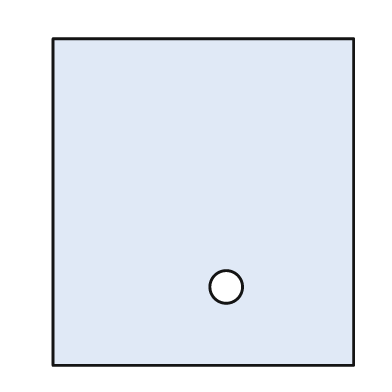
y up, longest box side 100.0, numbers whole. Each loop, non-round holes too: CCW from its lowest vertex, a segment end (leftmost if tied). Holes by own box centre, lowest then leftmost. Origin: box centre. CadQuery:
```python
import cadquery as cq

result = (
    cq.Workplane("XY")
    .moveTo(-46.0, -50.0)
    .lineTo(46.0, -50.0)
    .lineTo(46.0, 50.0)
    .lineTo(-46.0, 50.0)
    .close()
    .moveTo(7.0, -26.0)
    .circle(5.0)
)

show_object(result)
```